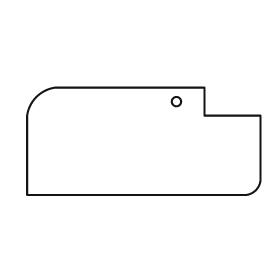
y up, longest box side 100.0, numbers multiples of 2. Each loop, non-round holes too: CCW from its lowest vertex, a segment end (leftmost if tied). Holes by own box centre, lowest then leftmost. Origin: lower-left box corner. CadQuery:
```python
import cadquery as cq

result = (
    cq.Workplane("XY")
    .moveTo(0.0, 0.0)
    .lineTo(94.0, 0.0)
    .threePointArc((98.0, 2.0), (100.0, 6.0))
    .lineTo(100.0, 34.0)
    .lineTo(76.0, 34.0)
    .lineTo(76.0, 46.0)
    .lineTo(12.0, 46.0)
    .threePointArc((4.0, 42.0), (0.0, 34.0))
    .close()
    .moveTo(64.0, 40.0)
    .circle(2.0)
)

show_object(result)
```